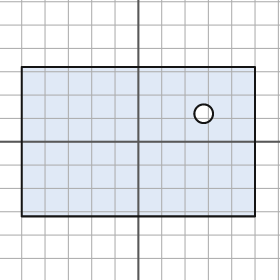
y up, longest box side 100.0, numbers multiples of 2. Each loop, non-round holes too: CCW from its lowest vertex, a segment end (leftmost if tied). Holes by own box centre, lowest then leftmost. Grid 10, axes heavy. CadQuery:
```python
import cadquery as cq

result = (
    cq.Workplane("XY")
    .moveTo(-50.0, -32.0)
    .lineTo(50.0, -32.0)
    .lineTo(50.0, 32.0)
    .lineTo(-50.0, 32.0)
    .close()
    .moveTo(28.0, 12.0)
    .circle(4.0)
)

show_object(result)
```